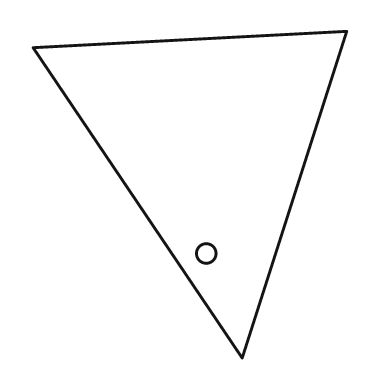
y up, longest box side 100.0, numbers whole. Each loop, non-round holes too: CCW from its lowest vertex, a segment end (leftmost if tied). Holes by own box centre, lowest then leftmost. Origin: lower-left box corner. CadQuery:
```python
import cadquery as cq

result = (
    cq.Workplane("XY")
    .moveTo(64.0, 0.0)
    .lineTo(96.0, 100.0)
    .lineTo(0.0, 95.0)
    .close()
    .moveTo(53.0, 32.0)
    .circle(3.0)
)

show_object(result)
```